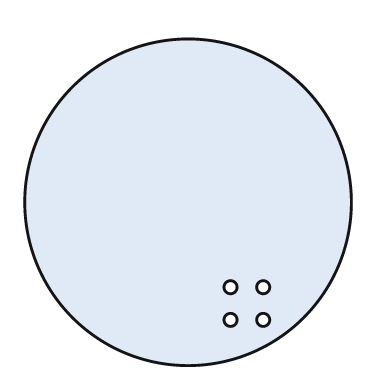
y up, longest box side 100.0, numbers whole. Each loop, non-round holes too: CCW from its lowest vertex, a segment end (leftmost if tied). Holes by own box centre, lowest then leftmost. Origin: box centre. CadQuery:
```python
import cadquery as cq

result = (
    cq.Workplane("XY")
    .moveTo(0.0, 0.0)
    .circle(50.0)
    .moveTo(13.0, -36.0)
    .circle(2.0)
    .moveTo(23.0, -36.0)
    .circle(2.0)
    .moveTo(13.0, -26.0)
    .circle(2.0)
    .moveTo(23.0, -26.0)
    .circle(2.0)
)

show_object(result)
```